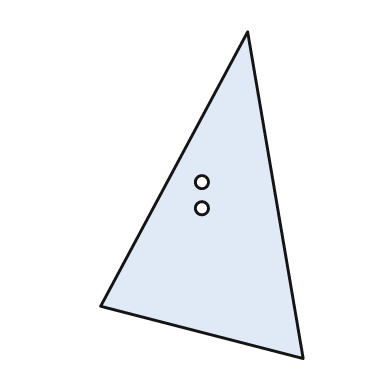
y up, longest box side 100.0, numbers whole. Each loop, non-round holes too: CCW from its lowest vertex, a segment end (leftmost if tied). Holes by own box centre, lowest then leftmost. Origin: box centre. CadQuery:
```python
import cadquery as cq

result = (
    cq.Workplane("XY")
    .moveTo(31.0, -50.0)
    .lineTo(14.0, 50.0)
    .lineTo(-31.0, -34.0)
    .close()
    .moveTo(0.0, -4.0)
    .circle(2.0)
    .moveTo(0.0, 4.0)
    .circle(2.0)
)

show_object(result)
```